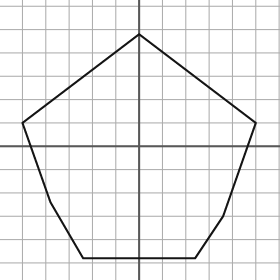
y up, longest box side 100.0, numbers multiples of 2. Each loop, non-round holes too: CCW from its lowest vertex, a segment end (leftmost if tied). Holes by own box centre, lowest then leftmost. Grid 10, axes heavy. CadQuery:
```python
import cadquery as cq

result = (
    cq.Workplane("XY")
    .moveTo(-24.0, -48.0)
    .lineTo(24.0, -48.0)
    .lineTo(36.0, -30.0)
    .lineTo(50.0, 10.0)
    .lineTo(0.0, 48.0)
    .lineTo(-50.0, 10.0)
    .lineTo(-38.0, -24.0)
    .close()
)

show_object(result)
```